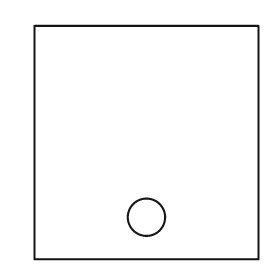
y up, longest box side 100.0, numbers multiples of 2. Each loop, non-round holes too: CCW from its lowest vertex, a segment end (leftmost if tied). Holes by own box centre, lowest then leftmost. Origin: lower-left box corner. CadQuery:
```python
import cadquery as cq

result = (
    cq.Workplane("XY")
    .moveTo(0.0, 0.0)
    .lineTo(96.0, 0.0)
    .lineTo(96.0, 100.0)
    .lineTo(0.0, 100.0)
    .close()
    .moveTo(48.0, 18.0)
    .circle(8.0)
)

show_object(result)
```